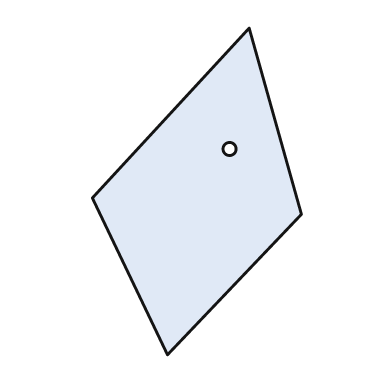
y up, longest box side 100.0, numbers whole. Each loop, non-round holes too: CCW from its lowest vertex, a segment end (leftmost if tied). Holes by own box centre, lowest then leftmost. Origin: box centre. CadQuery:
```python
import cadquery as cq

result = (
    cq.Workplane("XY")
    .moveTo(-9.0, -50.0)
    .lineTo(32.0, -7.0)
    .lineTo(16.0, 50.0)
    .lineTo(-32.0, -2.0)
    .close()
    .moveTo(10.0, 13.0)
    .circle(2.0)
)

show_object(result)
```